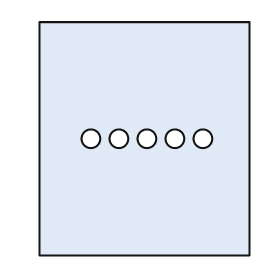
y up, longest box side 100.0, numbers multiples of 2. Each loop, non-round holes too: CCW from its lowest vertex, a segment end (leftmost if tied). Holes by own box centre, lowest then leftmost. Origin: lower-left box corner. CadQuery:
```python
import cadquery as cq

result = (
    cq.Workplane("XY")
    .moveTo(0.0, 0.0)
    .lineTo(90.0, 0.0)
    .lineTo(90.0, 100.0)
    .lineTo(0.0, 100.0)
    .close()
    .moveTo(22.0, 50.0)
    .circle(4.0)
    .moveTo(34.0, 50.0)
    .circle(4.0)
    .moveTo(46.0, 50.0)
    .circle(4.0)
    .moveTo(58.0, 50.0)
    .circle(4.0)
    .moveTo(70.0, 50.0)
    .circle(4.0)
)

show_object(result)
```